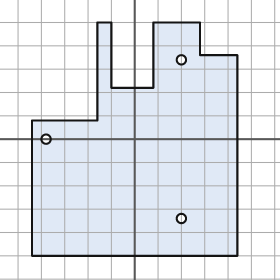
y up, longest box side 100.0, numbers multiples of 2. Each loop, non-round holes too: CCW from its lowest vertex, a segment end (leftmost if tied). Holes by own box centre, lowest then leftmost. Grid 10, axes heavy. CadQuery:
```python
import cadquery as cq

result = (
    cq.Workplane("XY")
    .moveTo(-44.0, -50.0)
    .lineTo(44.0, -50.0)
    .lineTo(44.0, 36.0)
    .lineTo(28.0, 36.0)
    .lineTo(28.0, 50.0)
    .lineTo(8.0, 50.0)
    .lineTo(8.0, 22.0)
    .lineTo(-10.0, 22.0)
    .lineTo(-10.0, 50.0)
    .lineTo(-16.0, 50.0)
    .lineTo(-16.0, 8.0)
    .lineTo(-44.0, 8.0)
    .close()
    .moveTo(20.0, -34.0)
    .circle(2.0)
    .moveTo(-38.0, 0.0)
    .circle(2.0)
    .moveTo(20.0, 34.0)
    .circle(2.0)
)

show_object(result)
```